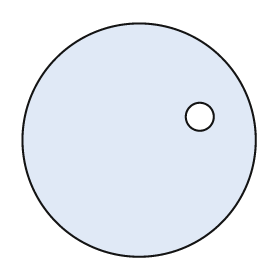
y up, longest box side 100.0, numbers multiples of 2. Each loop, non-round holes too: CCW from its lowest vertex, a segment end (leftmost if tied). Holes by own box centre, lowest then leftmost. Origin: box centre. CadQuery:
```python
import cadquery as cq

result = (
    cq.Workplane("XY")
    .moveTo(0.0, 0.0)
    .circle(50.0)
    .moveTo(26.0, 10.0)
    .circle(6.0)
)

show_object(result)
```